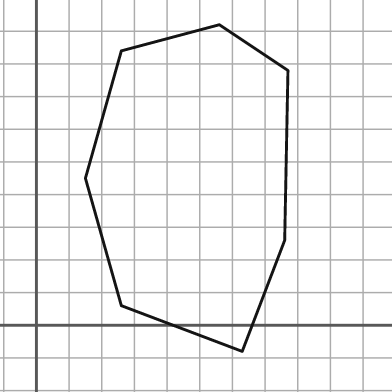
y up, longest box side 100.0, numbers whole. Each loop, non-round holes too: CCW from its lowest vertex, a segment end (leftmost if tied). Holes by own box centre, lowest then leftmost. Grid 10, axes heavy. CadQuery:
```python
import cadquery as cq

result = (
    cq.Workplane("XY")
    .moveTo(63.0, -8.0)
    .lineTo(76.0, 26.0)
    .lineTo(77.0, 78.0)
    .lineTo(56.0, 92.0)
    .lineTo(26.0, 84.0)
    .lineTo(15.0, 45.0)
    .lineTo(26.0, 6.0)
    .close()
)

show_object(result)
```